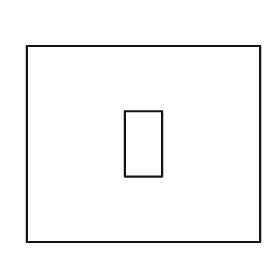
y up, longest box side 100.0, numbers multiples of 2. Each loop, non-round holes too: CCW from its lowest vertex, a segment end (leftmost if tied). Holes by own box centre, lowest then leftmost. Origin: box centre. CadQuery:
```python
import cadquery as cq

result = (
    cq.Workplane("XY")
    .moveTo(-50.0, -42.0)
    .lineTo(50.0, -42.0)
    .lineTo(50.0, 42.0)
    .lineTo(-50.0, 42.0)
    .close()
    .moveTo(-8.0, -14.0)
    .lineTo(8.0, -14.0)
    .lineTo(8.0, 14.0)
    .lineTo(-8.0, 14.0)
    .close()
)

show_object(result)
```